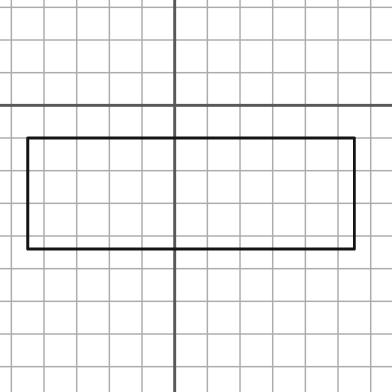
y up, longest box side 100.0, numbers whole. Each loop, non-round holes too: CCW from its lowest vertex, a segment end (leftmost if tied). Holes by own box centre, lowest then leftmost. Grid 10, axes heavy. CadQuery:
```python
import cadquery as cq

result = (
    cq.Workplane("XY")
    .moveTo(-45.0, -44.0)
    .lineTo(55.0, -44.0)
    .lineTo(55.0, -10.0)
    .lineTo(-45.0, -10.0)
    .close()
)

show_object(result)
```